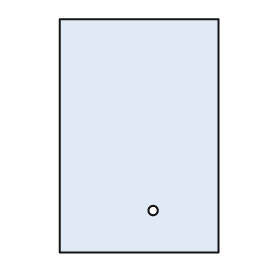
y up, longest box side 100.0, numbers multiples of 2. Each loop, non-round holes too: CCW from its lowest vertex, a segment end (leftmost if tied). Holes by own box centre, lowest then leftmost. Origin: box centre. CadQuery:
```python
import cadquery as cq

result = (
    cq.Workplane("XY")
    .moveTo(-34.0, -50.0)
    .lineTo(34.0, -50.0)
    .lineTo(34.0, 50.0)
    .lineTo(-34.0, 50.0)
    .close()
    .moveTo(6.0, -32.0)
    .circle(2.0)
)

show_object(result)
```